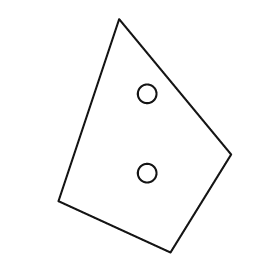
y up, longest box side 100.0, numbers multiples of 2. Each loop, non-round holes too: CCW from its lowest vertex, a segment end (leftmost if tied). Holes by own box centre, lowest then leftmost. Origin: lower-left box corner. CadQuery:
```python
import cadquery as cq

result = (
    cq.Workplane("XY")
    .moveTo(48.0, 0.0)
    .lineTo(74.0, 42.0)
    .lineTo(26.0, 100.0)
    .lineTo(0.0, 22.0)
    .close()
    .moveTo(38.0, 34.0)
    .circle(4.0)
    .moveTo(38.0, 68.0)
    .circle(4.0)
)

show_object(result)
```